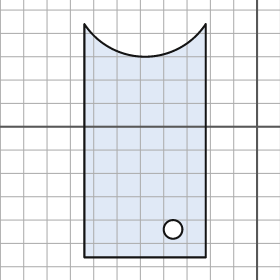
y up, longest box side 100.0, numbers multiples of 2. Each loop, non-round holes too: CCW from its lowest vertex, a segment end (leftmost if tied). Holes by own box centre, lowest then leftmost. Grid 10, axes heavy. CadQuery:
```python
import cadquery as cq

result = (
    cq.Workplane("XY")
    .moveTo(-74.0, -56.0)
    .lineTo(-22.0, -56.0)
    .lineTo(-22.0, 44.0)
    .threePointArc((-48.0, 30.0), (-74.0, 44.0))
    .close()
    .moveTo(-36.0, -44.0)
    .circle(4.0)
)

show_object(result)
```